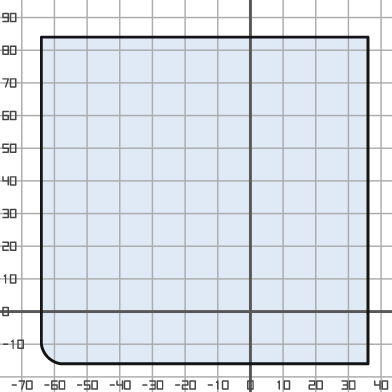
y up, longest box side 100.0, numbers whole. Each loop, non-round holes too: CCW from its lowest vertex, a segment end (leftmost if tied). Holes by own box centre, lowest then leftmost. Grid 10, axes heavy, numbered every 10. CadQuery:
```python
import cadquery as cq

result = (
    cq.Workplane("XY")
    .moveTo(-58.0, -16.0)
    .lineTo(36.0, -16.0)
    .lineTo(36.0, 84.0)
    .lineTo(-64.0, 84.0)
    .lineTo(-64.0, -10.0)
    .threePointArc((-62.0, -14.0), (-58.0, -16.0))
    .close()
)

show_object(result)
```